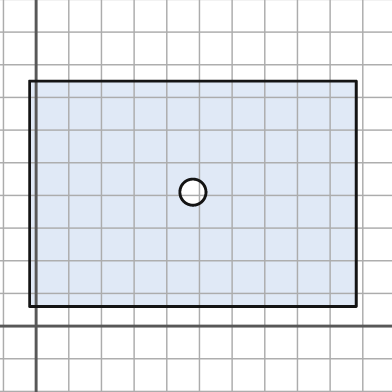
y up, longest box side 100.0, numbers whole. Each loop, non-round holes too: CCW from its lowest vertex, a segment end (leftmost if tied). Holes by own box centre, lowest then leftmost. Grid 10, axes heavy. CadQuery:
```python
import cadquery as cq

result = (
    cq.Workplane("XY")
    .moveTo(-2.0, 6.0)
    .lineTo(98.0, 6.0)
    .lineTo(98.0, 75.0)
    .lineTo(-2.0, 75.0)
    .close()
    .moveTo(48.0, 41.0)
    .circle(4.0)
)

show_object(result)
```